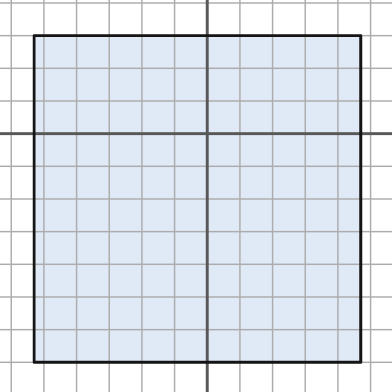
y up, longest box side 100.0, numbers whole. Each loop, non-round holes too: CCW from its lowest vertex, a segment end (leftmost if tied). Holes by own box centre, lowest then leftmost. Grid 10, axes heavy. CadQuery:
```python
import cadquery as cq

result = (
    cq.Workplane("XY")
    .moveTo(-53.0, -70.0)
    .lineTo(47.0, -70.0)
    .lineTo(47.0, 30.0)
    .lineTo(-53.0, 30.0)
    .close()
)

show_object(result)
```